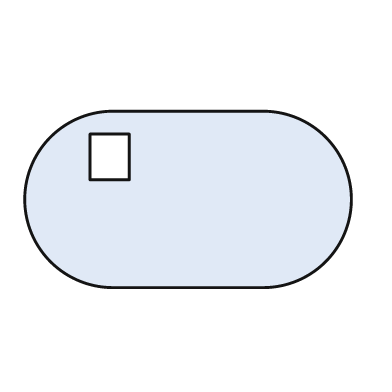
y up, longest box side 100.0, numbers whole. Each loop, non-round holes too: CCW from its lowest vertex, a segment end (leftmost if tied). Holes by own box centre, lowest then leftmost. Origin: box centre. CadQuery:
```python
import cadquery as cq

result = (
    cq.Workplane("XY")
    .moveTo(-23.0, -27.0)
    .lineTo(23.0, -27.0)
    .threePointArc((50.0, 0.0), (23.0, 27.0))
    .lineTo(-23.0, 27.0)
    .threePointArc((-50.0, 0.0), (-23.0, -27.0))
    .close()
    .moveTo(-30.0, 6.0)
    .lineTo(-18.0, 6.0)
    .lineTo(-18.0, 20.0)
    .lineTo(-30.0, 20.0)
    .close()
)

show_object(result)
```